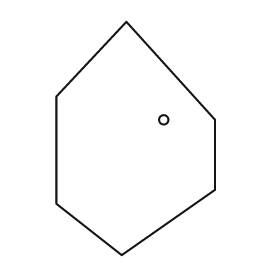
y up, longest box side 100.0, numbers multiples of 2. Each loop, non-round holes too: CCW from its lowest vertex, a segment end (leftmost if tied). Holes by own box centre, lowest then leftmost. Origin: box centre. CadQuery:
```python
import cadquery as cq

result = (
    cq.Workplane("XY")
    .moveTo(-6.0, -50.0)
    .lineTo(34.0, -22.0)
    .lineTo(34.0, 8.0)
    .lineTo(-4.0, 50.0)
    .lineTo(-34.0, 18.0)
    .lineTo(-34.0, -28.0)
    .close()
    .moveTo(12.0, 8.0)
    .circle(2.0)
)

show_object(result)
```